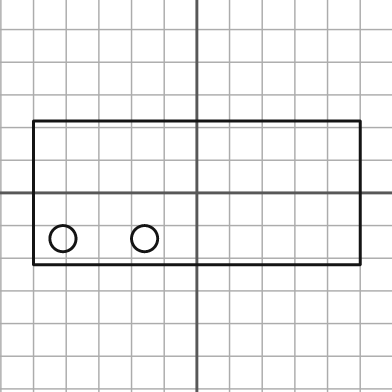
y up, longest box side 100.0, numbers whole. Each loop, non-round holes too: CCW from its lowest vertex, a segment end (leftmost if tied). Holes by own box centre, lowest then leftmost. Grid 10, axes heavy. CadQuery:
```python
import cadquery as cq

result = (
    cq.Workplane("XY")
    .moveTo(-50.0, -22.0)
    .lineTo(50.0, -22.0)
    .lineTo(50.0, 22.0)
    .lineTo(-50.0, 22.0)
    .close()
    .moveTo(-41.0, -14.0)
    .circle(4.0)
    .moveTo(-16.0, -14.0)
    .circle(4.0)
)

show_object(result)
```